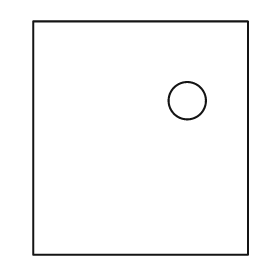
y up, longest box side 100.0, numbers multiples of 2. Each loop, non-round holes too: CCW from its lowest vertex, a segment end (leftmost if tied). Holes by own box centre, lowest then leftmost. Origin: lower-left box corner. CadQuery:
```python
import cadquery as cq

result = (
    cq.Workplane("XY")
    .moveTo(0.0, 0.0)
    .lineTo(92.0, 0.0)
    .lineTo(92.0, 100.0)
    .lineTo(0.0, 100.0)
    .close()
    .moveTo(66.0, 66.0)
    .circle(8.0)
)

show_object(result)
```